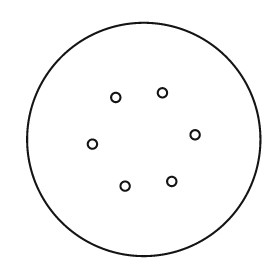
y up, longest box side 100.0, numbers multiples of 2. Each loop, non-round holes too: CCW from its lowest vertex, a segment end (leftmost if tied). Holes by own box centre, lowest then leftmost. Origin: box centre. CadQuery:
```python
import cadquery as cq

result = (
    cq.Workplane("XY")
    .moveTo(0.0, 0.0)
    .circle(50.0)
    .moveTo(-8.0, -20.0)
    .circle(2.0)
    .moveTo(12.0, -18.0)
    .circle(2.0)
    .moveTo(-22.0, -2.0)
    .circle(2.0)
    .moveTo(22.0, 2.0)
    .circle(2.0)
    .moveTo(-12.0, 18.0)
    .circle(2.0)
    .moveTo(8.0, 20.0)
    .circle(2.0)
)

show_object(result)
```